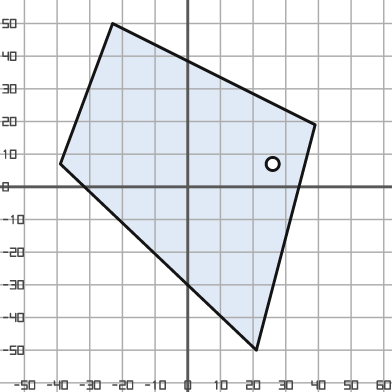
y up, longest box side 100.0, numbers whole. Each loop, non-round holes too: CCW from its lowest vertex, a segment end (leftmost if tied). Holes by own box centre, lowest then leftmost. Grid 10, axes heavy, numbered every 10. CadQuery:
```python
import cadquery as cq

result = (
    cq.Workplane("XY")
    .moveTo(21.0, -50.0)
    .lineTo(39.0, 19.0)
    .lineTo(-23.0, 50.0)
    .lineTo(-39.0, 7.0)
    .close()
    .moveTo(26.0, 7.0)
    .circle(2.0)
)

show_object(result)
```